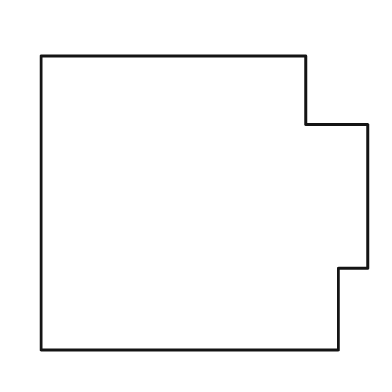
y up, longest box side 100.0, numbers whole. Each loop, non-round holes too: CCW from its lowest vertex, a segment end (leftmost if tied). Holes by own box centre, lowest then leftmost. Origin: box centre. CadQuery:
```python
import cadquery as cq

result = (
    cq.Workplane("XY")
    .moveTo(-50.0, -45.0)
    .lineTo(41.0, -45.0)
    .lineTo(41.0, -20.0)
    .lineTo(50.0, -20.0)
    .lineTo(50.0, 24.0)
    .lineTo(31.0, 24.0)
    .lineTo(31.0, 45.0)
    .lineTo(-50.0, 45.0)
    .close()
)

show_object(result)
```